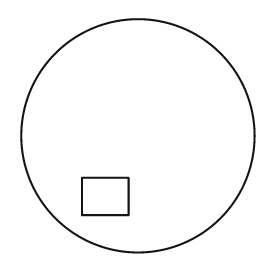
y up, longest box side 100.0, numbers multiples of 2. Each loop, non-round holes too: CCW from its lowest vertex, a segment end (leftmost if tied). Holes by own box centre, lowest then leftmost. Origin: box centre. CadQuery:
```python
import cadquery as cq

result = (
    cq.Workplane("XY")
    .moveTo(0.0, 0.0)
    .circle(50.0)
    .moveTo(-24.0, -34.0)
    .lineTo(-4.0, -34.0)
    .lineTo(-4.0, -18.0)
    .lineTo(-24.0, -18.0)
    .close()
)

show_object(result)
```